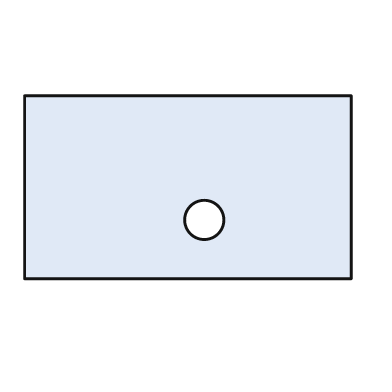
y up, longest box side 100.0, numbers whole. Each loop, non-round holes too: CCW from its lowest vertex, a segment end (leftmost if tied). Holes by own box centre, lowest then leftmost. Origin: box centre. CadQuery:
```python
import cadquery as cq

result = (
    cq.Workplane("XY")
    .moveTo(-50.0, -28.0)
    .lineTo(50.0, -28.0)
    .lineTo(50.0, 28.0)
    .lineTo(-50.0, 28.0)
    .close()
    .moveTo(5.0, -10.0)
    .circle(6.0)
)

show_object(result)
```